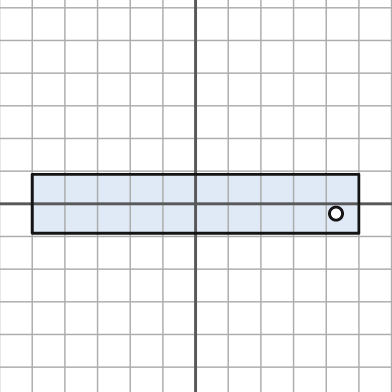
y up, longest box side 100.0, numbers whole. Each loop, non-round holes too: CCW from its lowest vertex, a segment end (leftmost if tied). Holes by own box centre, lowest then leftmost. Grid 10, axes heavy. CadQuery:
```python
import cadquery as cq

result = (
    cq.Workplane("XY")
    .moveTo(-50.0, -9.0)
    .lineTo(50.0, -9.0)
    .lineTo(50.0, 9.0)
    .lineTo(-50.0, 9.0)
    .close()
    .moveTo(43.0, -3.0)
    .circle(2.0)
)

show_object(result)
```